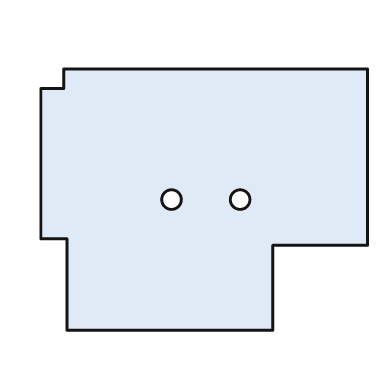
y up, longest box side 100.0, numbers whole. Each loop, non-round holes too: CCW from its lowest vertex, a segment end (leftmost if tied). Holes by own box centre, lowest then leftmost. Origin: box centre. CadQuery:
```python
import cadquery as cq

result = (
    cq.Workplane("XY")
    .moveTo(-42.0, -40.0)
    .lineTo(21.0, -40.0)
    .lineTo(21.0, -14.0)
    .lineTo(50.0, -14.0)
    .lineTo(50.0, 40.0)
    .lineTo(-43.0, 40.0)
    .lineTo(-43.0, 34.0)
    .lineTo(-50.0, 34.0)
    .lineTo(-50.0, -12.0)
    .lineTo(-42.0, -12.0)
    .close()
    .moveTo(-10.0, 0.0)
    .circle(3.0)
    .moveTo(11.0, 0.0)
    .circle(3.0)
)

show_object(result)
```